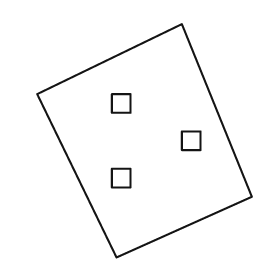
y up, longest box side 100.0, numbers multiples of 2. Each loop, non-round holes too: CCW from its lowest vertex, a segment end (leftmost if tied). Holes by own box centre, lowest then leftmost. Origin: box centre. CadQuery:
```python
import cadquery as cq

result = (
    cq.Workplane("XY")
    .moveTo(-12.0, -50.0)
    .lineTo(46.0, -24.0)
    .lineTo(16.0, 50.0)
    .lineTo(-46.0, 20.0)
    .close()
    .moveTo(-14.0, -20.0)
    .lineTo(-6.0, -20.0)
    .lineTo(-6.0, -12.0)
    .lineTo(-14.0, -12.0)
    .close()
    .moveTo(16.0, -4.0)
    .lineTo(24.0, -4.0)
    .lineTo(24.0, 4.0)
    .lineTo(16.0, 4.0)
    .close()
    .moveTo(-14.0, 12.0)
    .lineTo(-6.0, 12.0)
    .lineTo(-6.0, 20.0)
    .lineTo(-14.0, 20.0)
    .close()
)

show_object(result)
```